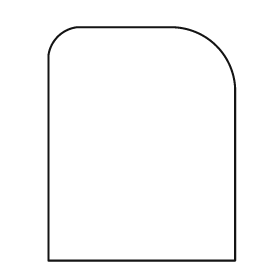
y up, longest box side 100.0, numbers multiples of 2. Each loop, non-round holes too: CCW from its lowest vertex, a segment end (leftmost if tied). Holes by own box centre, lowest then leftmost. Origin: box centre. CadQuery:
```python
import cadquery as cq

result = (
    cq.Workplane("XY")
    .moveTo(-40.0, -50.0)
    .lineTo(40.0, -50.0)
    .lineTo(40.0, 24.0)
    .threePointArc((32.0, 42.0), (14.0, 50.0))
    .lineTo(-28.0, 50.0)
    .threePointArc((-36.0, 46.0), (-40.0, 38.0))
    .close()
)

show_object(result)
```